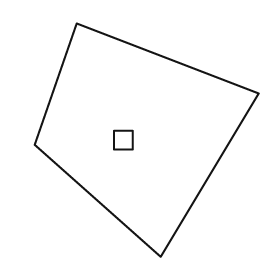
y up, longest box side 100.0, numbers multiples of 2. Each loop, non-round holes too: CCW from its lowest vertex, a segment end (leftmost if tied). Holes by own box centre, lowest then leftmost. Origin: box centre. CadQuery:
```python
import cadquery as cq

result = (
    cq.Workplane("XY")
    .moveTo(6.0, -50.0)
    .lineTo(48.0, 20.0)
    .lineTo(-30.0, 50.0)
    .lineTo(-48.0, -2.0)
    .close()
    .moveTo(-14.0, -4.0)
    .lineTo(-6.0, -4.0)
    .lineTo(-6.0, 4.0)
    .lineTo(-14.0, 4.0)
    .close()
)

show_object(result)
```